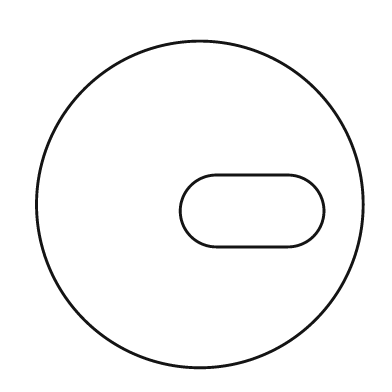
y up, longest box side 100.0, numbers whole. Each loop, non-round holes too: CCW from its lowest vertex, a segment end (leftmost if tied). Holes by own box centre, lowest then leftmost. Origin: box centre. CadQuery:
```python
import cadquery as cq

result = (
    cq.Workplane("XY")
    .moveTo(0.0, 0.0)
    .circle(50.0)
    .moveTo(5.0, -13.0)
    .lineTo(27.0, -13.0)
    .threePointArc((38.0, -2.0), (27.0, 9.0))
    .lineTo(5.0, 9.0)
    .threePointArc((-6.0, -2.0), (5.0, -13.0))
    .close()
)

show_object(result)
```